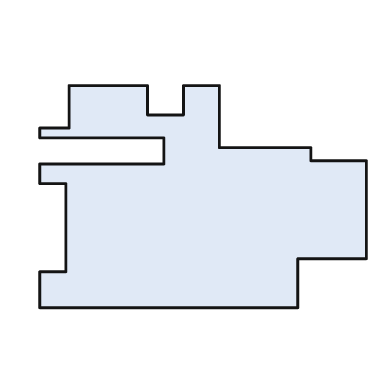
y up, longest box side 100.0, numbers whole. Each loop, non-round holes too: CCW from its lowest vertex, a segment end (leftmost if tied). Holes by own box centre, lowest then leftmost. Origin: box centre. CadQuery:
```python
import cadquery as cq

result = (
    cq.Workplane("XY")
    .moveTo(-50.0, -34.0)
    .lineTo(29.0, -34.0)
    .lineTo(29.0, -19.0)
    .lineTo(50.0, -19.0)
    .lineTo(50.0, 11.0)
    .lineTo(33.0, 11.0)
    .lineTo(33.0, 15.0)
    .lineTo(5.0, 15.0)
    .lineTo(5.0, 34.0)
    .lineTo(-6.0, 34.0)
    .lineTo(-6.0, 25.0)
    .lineTo(-17.0, 25.0)
    .lineTo(-17.0, 34.0)
    .lineTo(-41.0, 34.0)
    .lineTo(-41.0, 21.0)
    .lineTo(-50.0, 21.0)
    .lineTo(-50.0, 18.0)
    .lineTo(-12.0, 18.0)
    .lineTo(-12.0, 10.0)
    .lineTo(-50.0, 10.0)
    .lineTo(-50.0, 4.0)
    .lineTo(-42.0, 4.0)
    .lineTo(-42.0, -23.0)
    .lineTo(-50.0, -23.0)
    .close()
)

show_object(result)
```